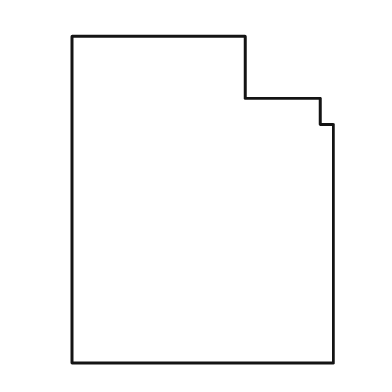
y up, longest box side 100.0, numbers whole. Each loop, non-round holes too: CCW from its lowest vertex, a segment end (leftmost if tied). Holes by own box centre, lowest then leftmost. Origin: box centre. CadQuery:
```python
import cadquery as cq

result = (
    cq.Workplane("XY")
    .moveTo(-40.0, -50.0)
    .lineTo(40.0, -50.0)
    .lineTo(40.0, 23.0)
    .lineTo(36.0, 23.0)
    .lineTo(36.0, 31.0)
    .lineTo(13.0, 31.0)
    .lineTo(13.0, 50.0)
    .lineTo(-40.0, 50.0)
    .close()
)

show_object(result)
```